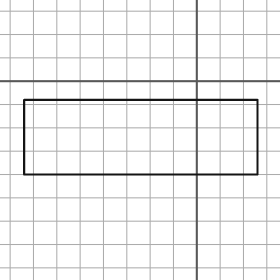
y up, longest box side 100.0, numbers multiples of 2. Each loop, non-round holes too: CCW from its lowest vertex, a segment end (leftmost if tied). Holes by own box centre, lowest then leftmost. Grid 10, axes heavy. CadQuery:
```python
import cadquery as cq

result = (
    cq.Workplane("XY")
    .moveTo(-74.0, -40.0)
    .lineTo(26.0, -40.0)
    .lineTo(26.0, -8.0)
    .lineTo(-74.0, -8.0)
    .close()
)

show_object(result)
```